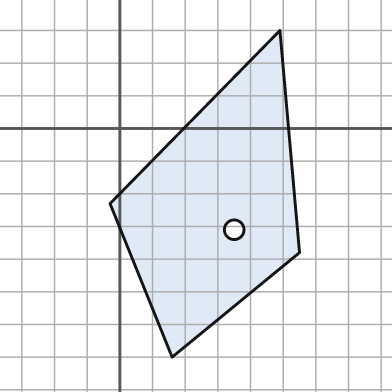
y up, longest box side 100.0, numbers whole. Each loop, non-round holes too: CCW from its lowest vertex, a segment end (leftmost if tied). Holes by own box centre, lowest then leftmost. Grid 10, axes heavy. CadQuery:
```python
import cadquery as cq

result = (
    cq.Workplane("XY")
    .moveTo(16.0, -70.0)
    .lineTo(55.0, -38.0)
    .lineTo(49.0, 30.0)
    .lineTo(-3.0, -23.0)
    .close()
    .moveTo(35.0, -31.0)
    .circle(3.0)
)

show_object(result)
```